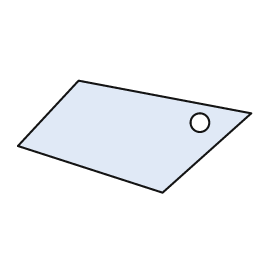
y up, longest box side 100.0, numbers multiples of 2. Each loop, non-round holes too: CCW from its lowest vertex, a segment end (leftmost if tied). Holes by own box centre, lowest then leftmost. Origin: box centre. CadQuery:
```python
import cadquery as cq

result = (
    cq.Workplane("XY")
    .moveTo(12.0, -24.0)
    .lineTo(50.0, 10.0)
    .lineTo(-24.0, 24.0)
    .lineTo(-50.0, -4.0)
    .close()
    .moveTo(28.0, 6.0)
    .circle(4.0)
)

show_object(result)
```